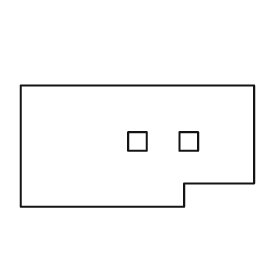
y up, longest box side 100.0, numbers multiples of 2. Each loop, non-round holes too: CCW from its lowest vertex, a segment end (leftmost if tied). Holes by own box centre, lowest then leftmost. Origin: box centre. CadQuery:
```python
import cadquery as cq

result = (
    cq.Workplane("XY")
    .moveTo(-50.0, -26.0)
    .lineTo(20.0, -26.0)
    .lineTo(20.0, -16.0)
    .lineTo(50.0, -16.0)
    .lineTo(50.0, 26.0)
    .lineTo(-50.0, 26.0)
    .close()
    .moveTo(-4.0, -2.0)
    .lineTo(4.0, -2.0)
    .lineTo(4.0, 6.0)
    .lineTo(-4.0, 6.0)
    .close()
    .moveTo(18.0, -2.0)
    .lineTo(26.0, -2.0)
    .lineTo(26.0, 6.0)
    .lineTo(18.0, 6.0)
    .close()
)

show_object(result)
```